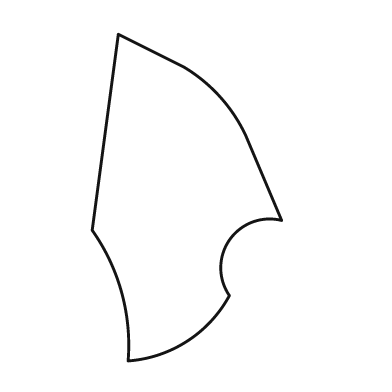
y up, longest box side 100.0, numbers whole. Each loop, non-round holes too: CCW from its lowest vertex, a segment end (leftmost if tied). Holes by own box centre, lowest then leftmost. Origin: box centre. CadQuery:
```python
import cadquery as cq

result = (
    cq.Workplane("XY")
    .moveTo(-18.0, -50.0)
    .threePointArc((0.0, -44.0), (13.0, -30.0))
    .threePointArc((13.0, -13.0), (29.0, -7.0))
    .lineTo(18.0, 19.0)
    .threePointArc((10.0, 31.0), (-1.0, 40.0))
    .lineTo(-21.0, 50.0)
    .lineTo(-29.0, -10.0)
    .threePointArc((-20.0, -29.0), (-18.0, -50.0))
    .close()
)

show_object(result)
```